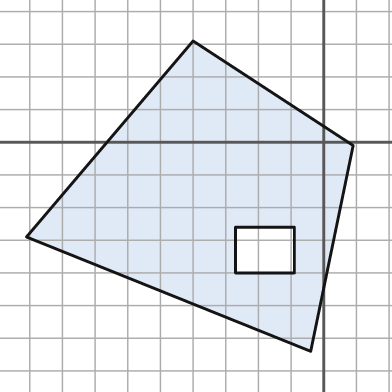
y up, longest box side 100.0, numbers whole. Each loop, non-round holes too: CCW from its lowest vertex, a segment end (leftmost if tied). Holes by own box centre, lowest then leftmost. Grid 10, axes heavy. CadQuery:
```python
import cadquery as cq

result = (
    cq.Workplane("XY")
    .moveTo(-4.0, -64.0)
    .lineTo(9.0, -1.0)
    .lineTo(-40.0, 31.0)
    .lineTo(-91.0, -29.0)
    .close()
    .moveTo(-27.0, -40.0)
    .lineTo(-9.0, -40.0)
    .lineTo(-9.0, -26.0)
    .lineTo(-27.0, -26.0)
    .close()
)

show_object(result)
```